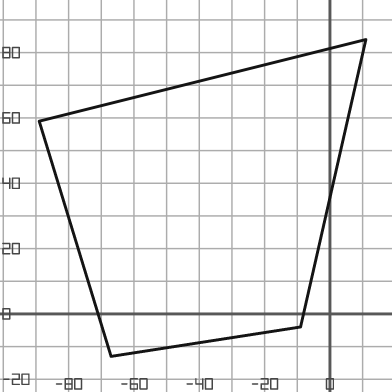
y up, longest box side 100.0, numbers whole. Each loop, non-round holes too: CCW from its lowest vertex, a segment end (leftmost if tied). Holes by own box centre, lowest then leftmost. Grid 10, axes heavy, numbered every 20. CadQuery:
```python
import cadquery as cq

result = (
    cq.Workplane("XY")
    .moveTo(-67.0, -13.0)
    .lineTo(-9.0, -4.0)
    .lineTo(11.0, 84.0)
    .lineTo(-89.0, 59.0)
    .close()
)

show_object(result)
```